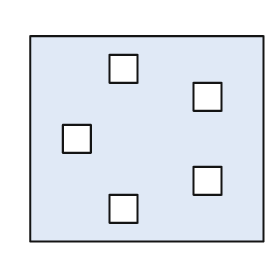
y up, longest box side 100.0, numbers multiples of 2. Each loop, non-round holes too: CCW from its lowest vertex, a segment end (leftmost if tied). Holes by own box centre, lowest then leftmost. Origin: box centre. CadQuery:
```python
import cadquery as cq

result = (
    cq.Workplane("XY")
    .moveTo(-50.0, -44.0)
    .lineTo(50.0, -44.0)
    .lineTo(50.0, 44.0)
    .lineTo(-50.0, 44.0)
    .close()
    .moveTo(-16.0, -36.0)
    .lineTo(-4.0, -36.0)
    .lineTo(-4.0, -24.0)
    .lineTo(-16.0, -24.0)
    .close()
    .moveTo(20.0, -24.0)
    .lineTo(32.0, -24.0)
    .lineTo(32.0, -12.0)
    .lineTo(20.0, -12.0)
    .close()
    .moveTo(-36.0, -6.0)
    .lineTo(-24.0, -6.0)
    .lineTo(-24.0, 6.0)
    .lineTo(-36.0, 6.0)
    .close()
    .moveTo(20.0, 12.0)
    .lineTo(32.0, 12.0)
    .lineTo(32.0, 24.0)
    .lineTo(20.0, 24.0)
    .close()
    .moveTo(-16.0, 24.0)
    .lineTo(-4.0, 24.0)
    .lineTo(-4.0, 36.0)
    .lineTo(-16.0, 36.0)
    .close()
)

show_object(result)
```